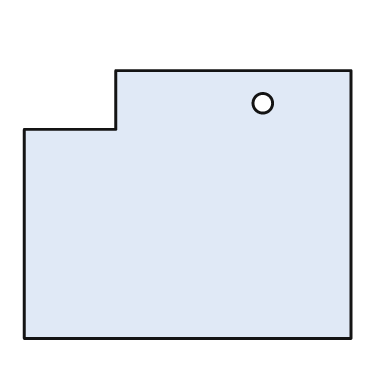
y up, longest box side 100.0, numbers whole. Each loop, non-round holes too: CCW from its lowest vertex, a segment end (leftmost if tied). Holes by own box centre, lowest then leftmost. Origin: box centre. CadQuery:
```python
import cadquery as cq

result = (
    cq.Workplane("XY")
    .moveTo(-50.0, -41.0)
    .lineTo(50.0, -41.0)
    .lineTo(50.0, 41.0)
    .lineTo(-22.0, 41.0)
    .lineTo(-22.0, 23.0)
    .lineTo(-50.0, 23.0)
    .close()
    .moveTo(23.0, 31.0)
    .circle(3.0)
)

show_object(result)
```